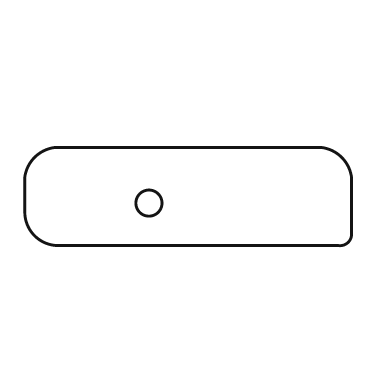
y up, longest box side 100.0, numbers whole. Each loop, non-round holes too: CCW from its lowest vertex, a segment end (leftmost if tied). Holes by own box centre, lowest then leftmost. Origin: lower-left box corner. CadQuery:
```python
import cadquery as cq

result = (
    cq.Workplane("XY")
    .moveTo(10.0, 0.0)
    .lineTo(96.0, 0.0)
    .threePointArc((99.0, 1.0), (100.0, 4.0))
    .lineTo(100.0, 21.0)
    .threePointArc((97.0, 27.0), (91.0, 30.0))
    .lineTo(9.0, 30.0)
    .threePointArc((3.0, 27.0), (0.0, 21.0))
    .lineTo(0.0, 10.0)
    .threePointArc((3.0, 3.0), (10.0, 0.0))
    .close()
    .moveTo(38.0, 13.0)
    .circle(4.0)
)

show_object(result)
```